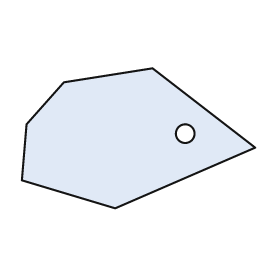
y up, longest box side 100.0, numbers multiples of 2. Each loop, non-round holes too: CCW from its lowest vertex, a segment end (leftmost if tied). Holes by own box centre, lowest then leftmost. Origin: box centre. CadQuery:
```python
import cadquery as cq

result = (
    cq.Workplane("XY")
    .moveTo(-10.0, -30.0)
    .lineTo(50.0, -4.0)
    .lineTo(6.0, 30.0)
    .lineTo(-32.0, 24.0)
    .lineTo(-48.0, 6.0)
    .lineTo(-50.0, -18.0)
    .close()
    .moveTo(20.0, 2.0)
    .circle(4.0)
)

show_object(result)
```